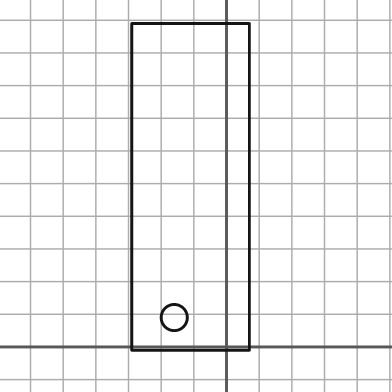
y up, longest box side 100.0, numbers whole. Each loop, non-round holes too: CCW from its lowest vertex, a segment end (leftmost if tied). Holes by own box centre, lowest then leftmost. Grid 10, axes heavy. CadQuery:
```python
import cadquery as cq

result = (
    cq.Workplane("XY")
    .moveTo(-29.0, -1.0)
    .lineTo(7.0, -1.0)
    .lineTo(7.0, 99.0)
    .lineTo(-29.0, 99.0)
    .close()
    .moveTo(-16.0, 9.0)
    .circle(4.0)
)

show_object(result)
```